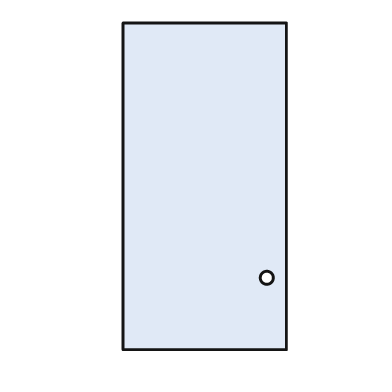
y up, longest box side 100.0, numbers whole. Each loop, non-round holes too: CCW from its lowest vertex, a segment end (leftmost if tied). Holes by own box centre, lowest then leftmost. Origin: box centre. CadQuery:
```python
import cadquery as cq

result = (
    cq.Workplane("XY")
    .moveTo(-25.0, -50.0)
    .lineTo(25.0, -50.0)
    .lineTo(25.0, 50.0)
    .lineTo(-25.0, 50.0)
    .close()
    .moveTo(19.0, -28.0)
    .circle(2.0)
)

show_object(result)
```